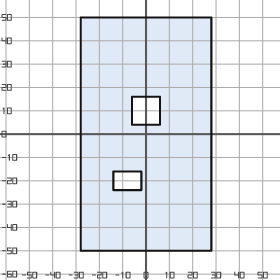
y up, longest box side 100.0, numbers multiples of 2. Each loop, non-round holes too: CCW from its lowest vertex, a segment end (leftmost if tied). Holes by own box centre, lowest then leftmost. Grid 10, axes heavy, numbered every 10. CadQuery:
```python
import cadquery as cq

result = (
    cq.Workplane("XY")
    .moveTo(-28.0, -50.0)
    .lineTo(28.0, -50.0)
    .lineTo(28.0, 50.0)
    .lineTo(-28.0, 50.0)
    .close()
    .moveTo(-14.0, -24.0)
    .lineTo(-2.0, -24.0)
    .lineTo(-2.0, -16.0)
    .lineTo(-14.0, -16.0)
    .close()
    .moveTo(-6.0, 4.0)
    .lineTo(6.0, 4.0)
    .lineTo(6.0, 16.0)
    .lineTo(-6.0, 16.0)
    .close()
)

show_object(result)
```